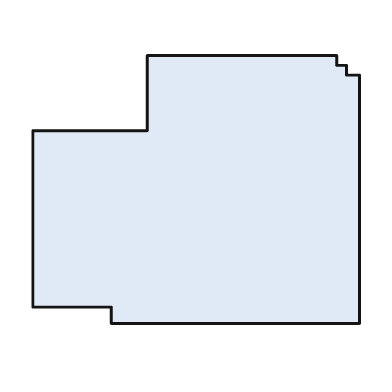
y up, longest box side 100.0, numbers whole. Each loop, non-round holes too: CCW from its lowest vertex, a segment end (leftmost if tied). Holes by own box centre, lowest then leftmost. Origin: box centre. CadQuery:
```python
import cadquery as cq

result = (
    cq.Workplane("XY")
    .moveTo(-26.0, -41.0)
    .lineTo(50.0, -41.0)
    .lineTo(50.0, 35.0)
    .lineTo(46.0, 35.0)
    .lineTo(46.0, 38.0)
    .lineTo(43.0, 38.0)
    .lineTo(43.0, 41.0)
    .lineTo(-15.0, 41.0)
    .lineTo(-15.0, 18.0)
    .lineTo(-50.0, 18.0)
    .lineTo(-50.0, -36.0)
    .lineTo(-26.0, -36.0)
    .close()
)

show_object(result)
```